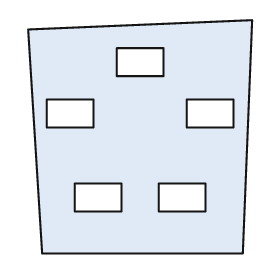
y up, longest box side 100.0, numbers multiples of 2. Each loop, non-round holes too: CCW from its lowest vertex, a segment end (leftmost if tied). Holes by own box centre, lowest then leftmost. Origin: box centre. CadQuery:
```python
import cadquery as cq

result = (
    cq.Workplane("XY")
    .moveTo(-42.0, -50.0)
    .lineTo(44.0, -50.0)
    .lineTo(48.0, 50.0)
    .lineTo(-48.0, 46.0)
    .close()
    .moveTo(-28.0, -32.0)
    .lineTo(-8.0, -32.0)
    .lineTo(-8.0, -20.0)
    .lineTo(-28.0, -20.0)
    .close()
    .moveTo(8.0, -32.0)
    .lineTo(28.0, -32.0)
    .lineTo(28.0, -20.0)
    .lineTo(8.0, -20.0)
    .close()
    .moveTo(-40.0, 4.0)
    .lineTo(-20.0, 4.0)
    .lineTo(-20.0, 16.0)
    .lineTo(-40.0, 16.0)
    .close()
    .moveTo(20.0, 4.0)
    .lineTo(40.0, 4.0)
    .lineTo(40.0, 16.0)
    .lineTo(20.0, 16.0)
    .close()
    .moveTo(-10.0, 26.0)
    .lineTo(10.0, 26.0)
    .lineTo(10.0, 38.0)
    .lineTo(-10.0, 38.0)
    .close()
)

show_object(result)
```